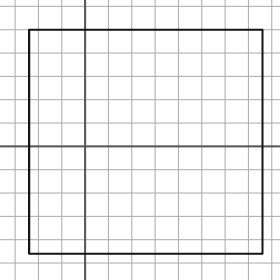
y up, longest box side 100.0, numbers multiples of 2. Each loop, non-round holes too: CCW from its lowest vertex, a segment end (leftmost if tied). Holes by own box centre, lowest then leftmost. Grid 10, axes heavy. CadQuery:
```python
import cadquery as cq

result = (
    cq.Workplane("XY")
    .moveTo(-24.0, -46.0)
    .lineTo(76.0, -46.0)
    .lineTo(76.0, 50.0)
    .lineTo(-24.0, 50.0)
    .close()
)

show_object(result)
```